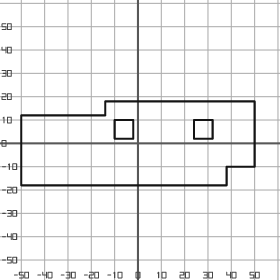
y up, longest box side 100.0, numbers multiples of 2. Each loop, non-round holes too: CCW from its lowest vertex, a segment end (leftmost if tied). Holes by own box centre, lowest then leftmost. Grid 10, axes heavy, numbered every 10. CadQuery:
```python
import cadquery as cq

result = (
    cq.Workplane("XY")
    .moveTo(-50.0, -18.0)
    .lineTo(38.0, -18.0)
    .lineTo(38.0, -10.0)
    .lineTo(50.0, -10.0)
    .lineTo(50.0, 18.0)
    .lineTo(-14.0, 18.0)
    .lineTo(-14.0, 12.0)
    .lineTo(-50.0, 12.0)
    .close()
    .moveTo(-10.0, 2.0)
    .lineTo(-2.0, 2.0)
    .lineTo(-2.0, 10.0)
    .lineTo(-10.0, 10.0)
    .close()
    .moveTo(24.0, 2.0)
    .lineTo(32.0, 2.0)
    .lineTo(32.0, 10.0)
    .lineTo(24.0, 10.0)
    .close()
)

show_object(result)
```